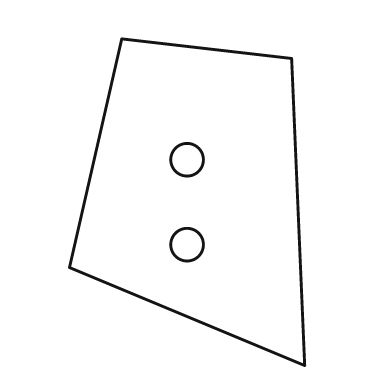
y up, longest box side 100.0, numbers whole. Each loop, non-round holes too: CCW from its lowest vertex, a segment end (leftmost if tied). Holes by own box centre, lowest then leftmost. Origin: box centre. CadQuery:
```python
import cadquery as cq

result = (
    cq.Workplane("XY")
    .moveTo(36.0, -50.0)
    .lineTo(32.0, 44.0)
    .lineTo(-20.0, 50.0)
    .lineTo(-36.0, -20.0)
    .close()
    .moveTo(0.0, -13.0)
    .circle(5.0)
    .moveTo(0.0, 13.0)
    .circle(5.0)
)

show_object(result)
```